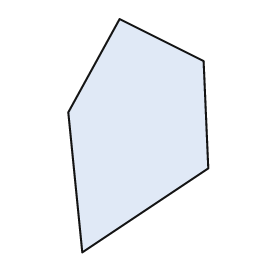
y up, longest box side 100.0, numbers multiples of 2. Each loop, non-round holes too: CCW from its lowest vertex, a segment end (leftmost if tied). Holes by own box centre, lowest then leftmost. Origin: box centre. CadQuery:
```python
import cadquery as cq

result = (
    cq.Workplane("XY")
    .moveTo(-24.0, -50.0)
    .lineTo(30.0, -14.0)
    .lineTo(28.0, 32.0)
    .lineTo(-8.0, 50.0)
    .lineTo(-30.0, 10.0)
    .close()
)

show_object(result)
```